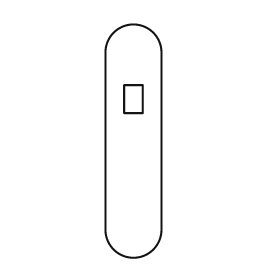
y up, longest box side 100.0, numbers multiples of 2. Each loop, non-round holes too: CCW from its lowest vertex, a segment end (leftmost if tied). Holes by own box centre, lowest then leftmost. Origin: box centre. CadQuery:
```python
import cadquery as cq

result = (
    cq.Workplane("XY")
    .moveTo(-12.0, -38.0)
    .threePointArc((0.0, -50.0), (12.0, -38.0))
    .lineTo(12.0, 38.0)
    .threePointArc((0.0, 50.0), (-12.0, 38.0))
    .close()
    .moveTo(-4.0, 12.0)
    .lineTo(4.0, 12.0)
    .lineTo(4.0, 24.0)
    .lineTo(-4.0, 24.0)
    .close()
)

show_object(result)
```